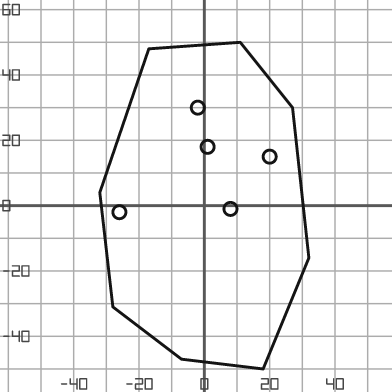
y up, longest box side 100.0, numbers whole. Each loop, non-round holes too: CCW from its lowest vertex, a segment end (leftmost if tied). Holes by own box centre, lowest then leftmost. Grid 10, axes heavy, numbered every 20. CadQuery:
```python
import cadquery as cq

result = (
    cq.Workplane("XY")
    .moveTo(18.0, -50.0)
    .lineTo(32.0, -16.0)
    .lineTo(27.0, 30.0)
    .lineTo(11.0, 50.0)
    .lineTo(-17.0, 48.0)
    .lineTo(-32.0, 4.0)
    .lineTo(-28.0, -31.0)
    .lineTo(-7.0, -47.0)
    .close()
    .moveTo(-26.0, -2.0)
    .circle(2.0)
    .moveTo(8.0, -1.0)
    .circle(2.0)
    .moveTo(20.0, 15.0)
    .circle(2.0)
    .moveTo(1.0, 18.0)
    .circle(2.0)
    .moveTo(-2.0, 30.0)
    .circle(2.0)
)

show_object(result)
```